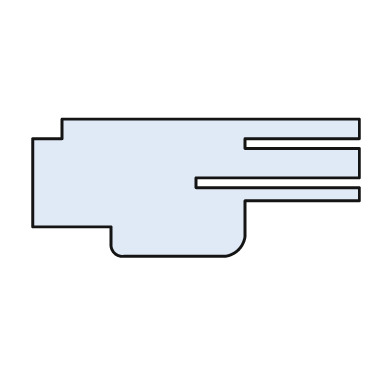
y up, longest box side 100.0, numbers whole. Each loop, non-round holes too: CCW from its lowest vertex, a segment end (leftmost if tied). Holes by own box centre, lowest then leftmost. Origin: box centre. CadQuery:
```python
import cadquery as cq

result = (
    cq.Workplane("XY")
    .moveTo(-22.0, -21.0)
    .lineTo(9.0, -21.0)
    .threePointArc((13.0, -19.0), (15.0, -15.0))
    .lineTo(15.0, -4.0)
    .lineTo(50.0, -4.0)
    .lineTo(50.0, 0.0)
    .lineTo(0.0, 0.0)
    .lineTo(0.0, 3.0)
    .lineTo(50.0, 3.0)
    .lineTo(50.0, 12.0)
    .lineTo(15.0, 12.0)
    .lineTo(15.0, 15.0)
    .lineTo(50.0, 15.0)
    .lineTo(50.0, 21.0)
    .lineTo(-41.0, 21.0)
    .lineTo(-41.0, 15.0)
    .lineTo(-50.0, 15.0)
    .lineTo(-50.0, -12.0)
    .lineTo(-26.0, -12.0)
    .lineTo(-26.0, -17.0)
    .threePointArc((-25.0, -20.0), (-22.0, -21.0))
    .close()
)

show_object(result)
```